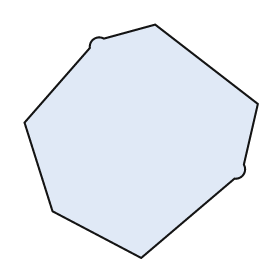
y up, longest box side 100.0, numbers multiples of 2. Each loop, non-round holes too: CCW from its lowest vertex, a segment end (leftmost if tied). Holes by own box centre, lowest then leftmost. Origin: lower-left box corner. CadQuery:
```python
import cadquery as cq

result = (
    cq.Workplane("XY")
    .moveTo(50.0, 0.0)
    .lineTo(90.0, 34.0)
    .threePointArc((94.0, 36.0), (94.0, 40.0))
    .lineTo(100.0, 66.0)
    .lineTo(56.0, 100.0)
    .lineTo(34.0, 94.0)
    .threePointArc((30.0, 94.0), (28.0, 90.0))
    .lineTo(0.0, 58.0)
    .lineTo(12.0, 20.0)
    .close()
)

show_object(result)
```